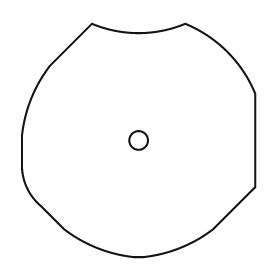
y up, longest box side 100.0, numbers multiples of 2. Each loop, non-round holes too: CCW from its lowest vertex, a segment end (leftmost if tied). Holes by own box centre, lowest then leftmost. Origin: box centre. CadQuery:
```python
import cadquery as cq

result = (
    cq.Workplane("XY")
    .moveTo(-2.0, -50.0)
    .lineTo(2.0, -50.0)
    .threePointArc((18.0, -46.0), (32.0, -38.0))
    .lineTo(50.0, -20.0)
    .lineTo(50.0, 20.0)
    .threePointArc((38.0, 38.0), (20.0, 50.0))
    .threePointArc((0.0, 46.0), (-20.0, 50.0))
    .lineTo(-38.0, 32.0)
    .threePointArc((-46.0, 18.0), (-50.0, 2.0))
    .lineTo(-50.0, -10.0)
    .threePointArc((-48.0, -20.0), (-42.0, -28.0))
    .lineTo(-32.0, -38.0)
    .threePointArc((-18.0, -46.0), (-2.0, -50.0))
    .close()
    .moveTo(0.0, 0.0)
    .circle(4.0)
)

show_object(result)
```